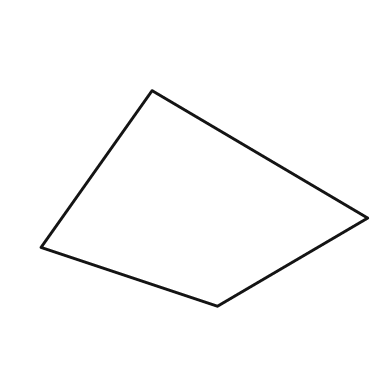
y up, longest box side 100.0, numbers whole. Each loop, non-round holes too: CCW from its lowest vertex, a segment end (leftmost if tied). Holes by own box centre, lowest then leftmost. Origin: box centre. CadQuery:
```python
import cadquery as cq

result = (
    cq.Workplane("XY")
    .moveTo(4.0, -33.0)
    .lineTo(50.0, -6.0)
    .lineTo(-16.0, 33.0)
    .lineTo(-50.0, -15.0)
    .close()
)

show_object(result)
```